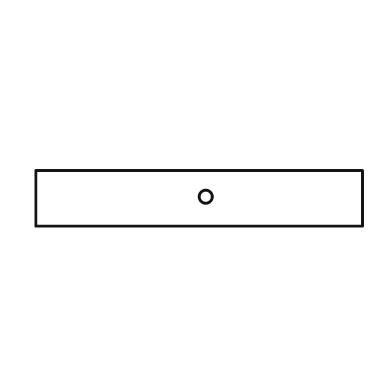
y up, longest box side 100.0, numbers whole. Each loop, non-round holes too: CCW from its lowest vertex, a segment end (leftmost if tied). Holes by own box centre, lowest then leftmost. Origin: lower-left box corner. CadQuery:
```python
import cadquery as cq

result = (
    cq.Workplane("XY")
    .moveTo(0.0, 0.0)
    .lineTo(100.0, 0.0)
    .lineTo(100.0, 17.0)
    .lineTo(0.0, 17.0)
    .close()
    .moveTo(52.0, 9.0)
    .circle(2.0)
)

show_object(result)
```